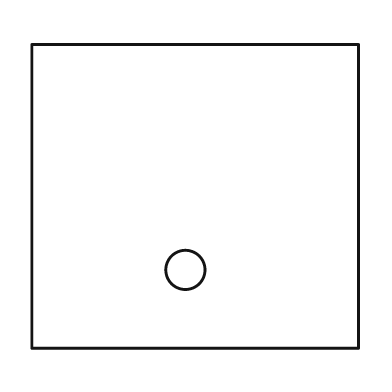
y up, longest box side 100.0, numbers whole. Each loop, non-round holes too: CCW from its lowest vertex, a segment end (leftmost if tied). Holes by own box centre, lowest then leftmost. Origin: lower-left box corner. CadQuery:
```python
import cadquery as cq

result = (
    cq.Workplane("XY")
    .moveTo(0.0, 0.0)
    .lineTo(100.0, 0.0)
    .lineTo(100.0, 93.0)
    .lineTo(0.0, 93.0)
    .close()
    .moveTo(47.0, 24.0)
    .circle(6.0)
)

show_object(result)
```